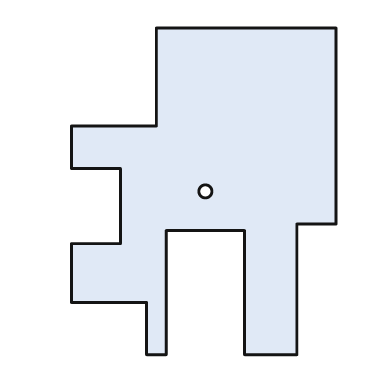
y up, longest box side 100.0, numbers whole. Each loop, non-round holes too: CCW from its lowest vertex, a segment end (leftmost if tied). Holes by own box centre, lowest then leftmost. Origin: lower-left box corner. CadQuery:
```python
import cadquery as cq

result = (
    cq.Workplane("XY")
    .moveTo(23.0, 0.0)
    .lineTo(29.0, 0.0)
    .lineTo(29.0, 38.0)
    .lineTo(53.0, 38.0)
    .lineTo(53.0, 0.0)
    .lineTo(69.0, 0.0)
    .lineTo(69.0, 40.0)
    .lineTo(81.0, 40.0)
    .lineTo(81.0, 100.0)
    .lineTo(26.0, 100.0)
    .lineTo(26.0, 70.0)
    .lineTo(0.0, 70.0)
    .lineTo(0.0, 57.0)
    .lineTo(15.0, 57.0)
    .lineTo(15.0, 34.0)
    .lineTo(0.0, 34.0)
    .lineTo(0.0, 16.0)
    .lineTo(23.0, 16.0)
    .close()
    .moveTo(41.0, 50.0)
    .circle(2.0)
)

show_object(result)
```